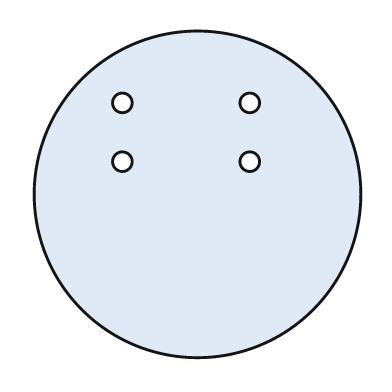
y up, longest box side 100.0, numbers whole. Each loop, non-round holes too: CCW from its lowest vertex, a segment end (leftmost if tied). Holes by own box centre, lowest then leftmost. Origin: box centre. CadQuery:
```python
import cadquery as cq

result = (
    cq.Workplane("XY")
    .moveTo(0.0, 0.0)
    .circle(50.0)
    .moveTo(-23.0, 10.0)
    .circle(3.0)
    .moveTo(16.0, 10.0)
    .circle(3.0)
    .moveTo(-23.0, 28.0)
    .circle(3.0)
    .moveTo(16.0, 28.0)
    .circle(3.0)
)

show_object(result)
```